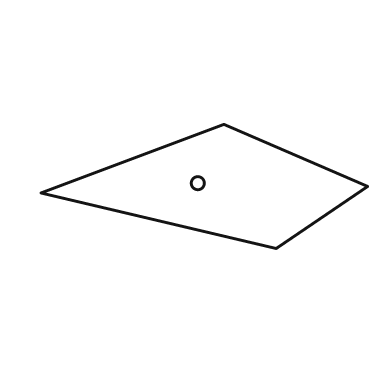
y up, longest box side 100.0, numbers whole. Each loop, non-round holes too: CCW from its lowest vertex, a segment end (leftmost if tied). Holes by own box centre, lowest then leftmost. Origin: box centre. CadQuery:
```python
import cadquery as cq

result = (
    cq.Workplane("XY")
    .moveTo(22.0, -19.0)
    .lineTo(50.0, 0.0)
    .lineTo(6.0, 19.0)
    .lineTo(-50.0, -2.0)
    .close()
    .moveTo(-2.0, 1.0)
    .circle(2.0)
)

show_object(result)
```